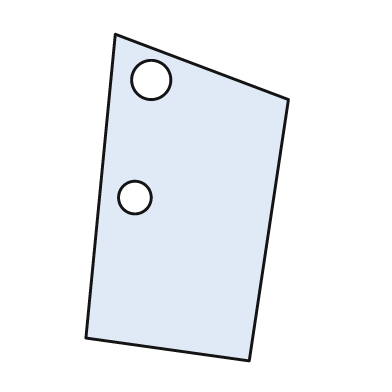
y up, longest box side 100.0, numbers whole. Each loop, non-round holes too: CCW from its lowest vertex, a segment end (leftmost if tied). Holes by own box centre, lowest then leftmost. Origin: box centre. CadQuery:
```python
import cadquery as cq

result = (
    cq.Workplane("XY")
    .moveTo(19.0, -50.0)
    .lineTo(31.0, 30.0)
    .lineTo(-22.0, 50.0)
    .lineTo(-31.0, -43.0)
    .close()
    .moveTo(-16.0, 0.0)
    .circle(5.0)
    .moveTo(-11.0, 36.0)
    .circle(6.0)
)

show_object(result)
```